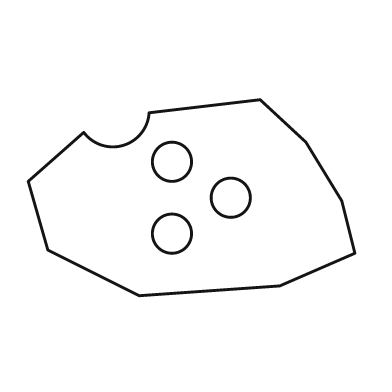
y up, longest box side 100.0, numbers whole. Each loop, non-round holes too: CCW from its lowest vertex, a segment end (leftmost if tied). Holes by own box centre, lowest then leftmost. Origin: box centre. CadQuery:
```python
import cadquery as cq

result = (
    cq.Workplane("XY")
    .moveTo(-16.0, -30.0)
    .lineTo(27.0, -27.0)
    .lineTo(50.0, -17.0)
    .lineTo(46.0, -1.0)
    .lineTo(35.0, 17.0)
    .lineTo(21.0, 30.0)
    .lineTo(-13.0, 26.0)
    .threePointArc((-21.0, 16.0), (-33.0, 20.0))
    .lineTo(-50.0, 5.0)
    .lineTo(-44.0, -16.0)
    .close()
    .moveTo(-6.0, -11.0)
    .circle(6.0)
    .moveTo(12.0, 0.0)
    .circle(6.0)
    .moveTo(-6.0, 11.0)
    .circle(6.0)
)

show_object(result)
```